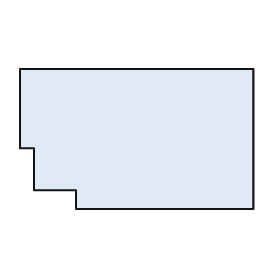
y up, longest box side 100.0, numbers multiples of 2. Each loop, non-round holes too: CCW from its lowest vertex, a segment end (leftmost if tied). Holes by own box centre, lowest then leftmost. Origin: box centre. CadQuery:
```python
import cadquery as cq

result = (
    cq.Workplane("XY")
    .moveTo(-26.0, -30.0)
    .lineTo(50.0, -30.0)
    .lineTo(50.0, 30.0)
    .lineTo(-50.0, 30.0)
    .lineTo(-50.0, -4.0)
    .lineTo(-44.0, -4.0)
    .lineTo(-44.0, -22.0)
    .lineTo(-26.0, -22.0)
    .close()
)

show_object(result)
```